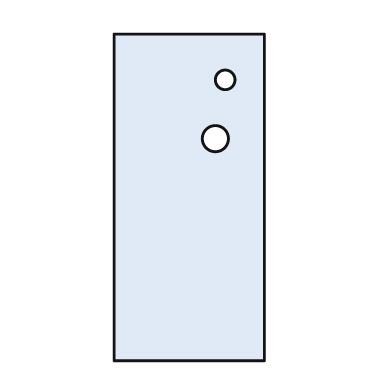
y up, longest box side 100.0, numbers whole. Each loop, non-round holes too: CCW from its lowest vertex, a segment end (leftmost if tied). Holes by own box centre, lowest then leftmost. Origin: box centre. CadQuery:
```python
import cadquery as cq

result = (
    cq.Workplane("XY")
    .moveTo(-23.0, -50.0)
    .lineTo(23.0, -50.0)
    .lineTo(23.0, 50.0)
    .lineTo(-23.0, 50.0)
    .close()
    .moveTo(8.0, 18.0)
    .circle(4.0)
    .moveTo(11.0, 36.0)
    .circle(3.0)
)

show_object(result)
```